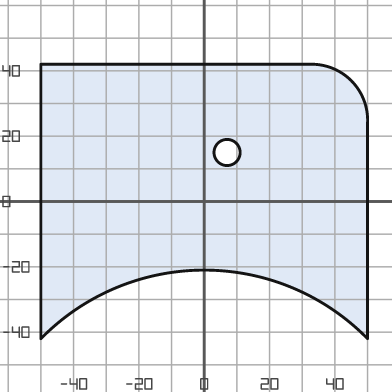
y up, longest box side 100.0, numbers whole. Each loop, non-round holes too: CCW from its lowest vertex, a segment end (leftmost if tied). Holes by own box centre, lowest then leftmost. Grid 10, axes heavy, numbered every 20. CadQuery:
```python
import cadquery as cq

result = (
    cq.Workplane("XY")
    .moveTo(-50.0, -42.0)
    .threePointArc((0.0, -21.0), (50.0, -42.0))
    .lineTo(50.0, 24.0)
    .threePointArc((45.0, 37.0), (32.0, 42.0))
    .lineTo(-50.0, 42.0)
    .close()
    .moveTo(7.0, 15.0)
    .circle(4.0)
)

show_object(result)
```